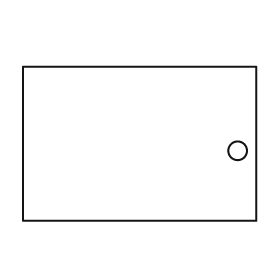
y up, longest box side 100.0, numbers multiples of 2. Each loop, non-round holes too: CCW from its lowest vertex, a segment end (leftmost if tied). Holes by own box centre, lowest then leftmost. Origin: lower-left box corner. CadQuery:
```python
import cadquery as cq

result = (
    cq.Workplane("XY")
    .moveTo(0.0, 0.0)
    .lineTo(100.0, 0.0)
    .lineTo(100.0, 66.0)
    .lineTo(0.0, 66.0)
    .close()
    .moveTo(92.0, 30.0)
    .circle(4.0)
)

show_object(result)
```